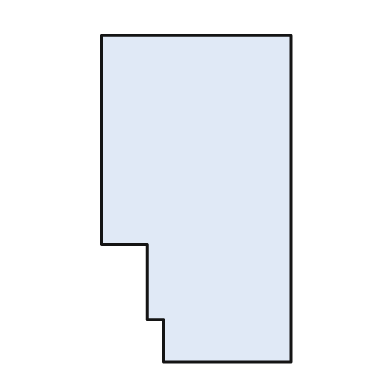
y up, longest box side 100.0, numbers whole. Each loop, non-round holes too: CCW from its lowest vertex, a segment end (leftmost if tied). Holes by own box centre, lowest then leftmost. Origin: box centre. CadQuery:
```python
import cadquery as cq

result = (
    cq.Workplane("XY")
    .moveTo(-10.0, -50.0)
    .lineTo(29.0, -50.0)
    .lineTo(29.0, 50.0)
    .lineTo(-29.0, 50.0)
    .lineTo(-29.0, -14.0)
    .lineTo(-15.0, -14.0)
    .lineTo(-15.0, -37.0)
    .lineTo(-10.0, -37.0)
    .close()
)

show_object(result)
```